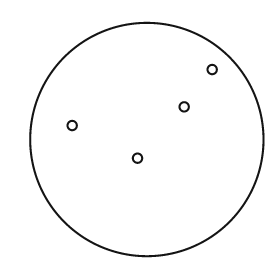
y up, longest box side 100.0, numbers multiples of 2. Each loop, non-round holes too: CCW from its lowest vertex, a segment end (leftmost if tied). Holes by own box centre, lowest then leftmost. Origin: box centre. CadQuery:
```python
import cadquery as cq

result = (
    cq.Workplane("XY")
    .moveTo(0.0, 0.0)
    .circle(50.0)
    .moveTo(-4.0, -8.0)
    .circle(2.0)
    .moveTo(-32.0, 6.0)
    .circle(2.0)
    .moveTo(16.0, 14.0)
    .circle(2.0)
    .moveTo(28.0, 30.0)
    .circle(2.0)
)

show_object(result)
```